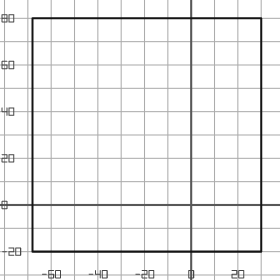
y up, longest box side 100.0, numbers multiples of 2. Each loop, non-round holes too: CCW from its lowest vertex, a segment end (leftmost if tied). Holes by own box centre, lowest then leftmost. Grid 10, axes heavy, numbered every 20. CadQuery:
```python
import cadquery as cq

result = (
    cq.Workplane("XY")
    .moveTo(-68.0, -20.0)
    .lineTo(30.0, -20.0)
    .lineTo(30.0, 80.0)
    .lineTo(-68.0, 80.0)
    .close()
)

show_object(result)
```